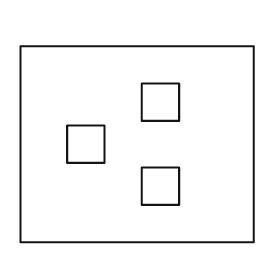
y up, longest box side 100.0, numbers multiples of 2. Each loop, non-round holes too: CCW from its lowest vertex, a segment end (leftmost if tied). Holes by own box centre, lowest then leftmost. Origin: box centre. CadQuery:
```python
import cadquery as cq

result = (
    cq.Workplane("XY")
    .moveTo(-50.0, -42.0)
    .lineTo(50.0, -42.0)
    .lineTo(50.0, 42.0)
    .lineTo(-50.0, 42.0)
    .close()
    .moveTo(2.0, -26.0)
    .lineTo(18.0, -26.0)
    .lineTo(18.0, -10.0)
    .lineTo(2.0, -10.0)
    .close()
    .moveTo(-30.0, -8.0)
    .lineTo(-14.0, -8.0)
    .lineTo(-14.0, 8.0)
    .lineTo(-30.0, 8.0)
    .close()
    .moveTo(2.0, 10.0)
    .lineTo(18.0, 10.0)
    .lineTo(18.0, 26.0)
    .lineTo(2.0, 26.0)
    .close()
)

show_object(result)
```